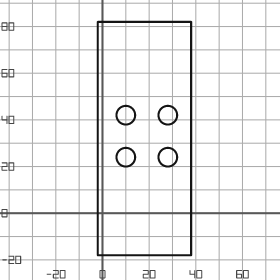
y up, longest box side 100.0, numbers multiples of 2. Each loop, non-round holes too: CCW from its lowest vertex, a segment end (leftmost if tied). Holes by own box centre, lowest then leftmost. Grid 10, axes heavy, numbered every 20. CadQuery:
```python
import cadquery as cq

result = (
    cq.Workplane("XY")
    .moveTo(-2.0, -18.0)
    .lineTo(38.0, -18.0)
    .lineTo(38.0, 82.0)
    .lineTo(-2.0, 82.0)
    .close()
    .moveTo(10.0, 24.0)
    .circle(4.0)
    .moveTo(28.0, 24.0)
    .circle(4.0)
    .moveTo(10.0, 42.0)
    .circle(4.0)
    .moveTo(28.0, 42.0)
    .circle(4.0)
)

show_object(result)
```